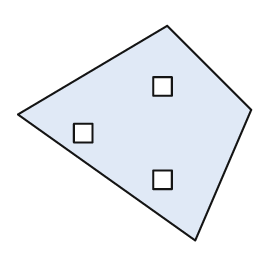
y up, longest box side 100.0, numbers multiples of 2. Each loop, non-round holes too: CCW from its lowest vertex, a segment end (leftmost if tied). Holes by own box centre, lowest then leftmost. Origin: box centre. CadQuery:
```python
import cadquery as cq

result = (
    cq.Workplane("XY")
    .moveTo(26.0, -46.0)
    .lineTo(50.0, 10.0)
    .lineTo(14.0, 46.0)
    .lineTo(-50.0, 8.0)
    .close()
    .moveTo(8.0, -24.0)
    .lineTo(16.0, -24.0)
    .lineTo(16.0, -16.0)
    .lineTo(8.0, -16.0)
    .close()
    .moveTo(-26.0, -4.0)
    .lineTo(-18.0, -4.0)
    .lineTo(-18.0, 4.0)
    .lineTo(-26.0, 4.0)
    .close()
    .moveTo(8.0, 16.0)
    .lineTo(16.0, 16.0)
    .lineTo(16.0, 24.0)
    .lineTo(8.0, 24.0)
    .close()
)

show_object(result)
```